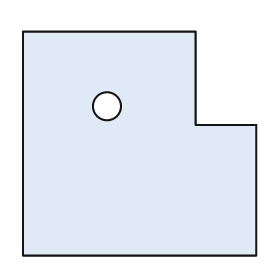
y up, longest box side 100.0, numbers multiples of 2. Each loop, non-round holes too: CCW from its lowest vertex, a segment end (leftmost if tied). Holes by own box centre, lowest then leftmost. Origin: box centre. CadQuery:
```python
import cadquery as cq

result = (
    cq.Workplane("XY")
    .moveTo(-50.0, -48.0)
    .lineTo(50.0, -48.0)
    .lineTo(50.0, 8.0)
    .lineTo(24.0, 8.0)
    .lineTo(24.0, 48.0)
    .lineTo(-50.0, 48.0)
    .close()
    .moveTo(-14.0, 16.0)
    .circle(6.0)
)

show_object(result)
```